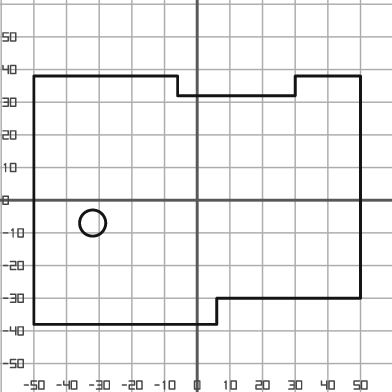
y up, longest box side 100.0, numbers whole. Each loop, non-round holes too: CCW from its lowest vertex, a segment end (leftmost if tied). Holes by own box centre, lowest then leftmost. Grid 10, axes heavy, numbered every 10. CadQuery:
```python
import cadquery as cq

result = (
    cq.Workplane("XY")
    .moveTo(-50.0, -38.0)
    .lineTo(6.0, -38.0)
    .lineTo(6.0, -30.0)
    .lineTo(50.0, -30.0)
    .lineTo(50.0, 38.0)
    .lineTo(30.0, 38.0)
    .lineTo(30.0, 32.0)
    .lineTo(-6.0, 32.0)
    .lineTo(-6.0, 38.0)
    .lineTo(-50.0, 38.0)
    .close()
    .moveTo(-32.0, -7.0)
    .circle(4.0)
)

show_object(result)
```